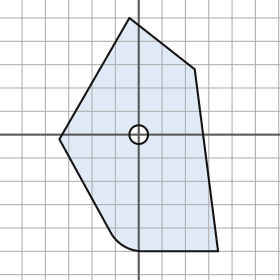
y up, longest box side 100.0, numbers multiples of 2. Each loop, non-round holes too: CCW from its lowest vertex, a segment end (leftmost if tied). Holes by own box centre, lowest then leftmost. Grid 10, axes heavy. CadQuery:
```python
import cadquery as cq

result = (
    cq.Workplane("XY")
    .moveTo(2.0, -50.0)
    .lineTo(34.0, -50.0)
    .lineTo(24.0, 28.0)
    .lineTo(-4.0, 50.0)
    .lineTo(-34.0, -2.0)
    .lineTo(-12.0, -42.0)
    .threePointArc((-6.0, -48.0), (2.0, -50.0))
    .close()
    .moveTo(0.0, 0.0)
    .circle(4.0)
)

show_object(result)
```